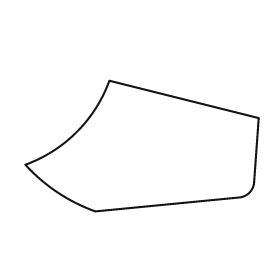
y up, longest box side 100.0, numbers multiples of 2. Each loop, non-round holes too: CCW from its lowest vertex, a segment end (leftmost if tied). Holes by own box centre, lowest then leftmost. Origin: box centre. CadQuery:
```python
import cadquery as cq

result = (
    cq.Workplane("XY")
    .moveTo(-20.0, -28.0)
    .lineTo(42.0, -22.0)
    .threePointArc((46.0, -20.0), (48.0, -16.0))
    .lineTo(50.0, 12.0)
    .lineTo(-14.0, 28.0)
    .threePointArc((-28.0, 6.0), (-50.0, -8.0))
    .threePointArc((-36.0, -20.0), (-20.0, -28.0))
    .close()
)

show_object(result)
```